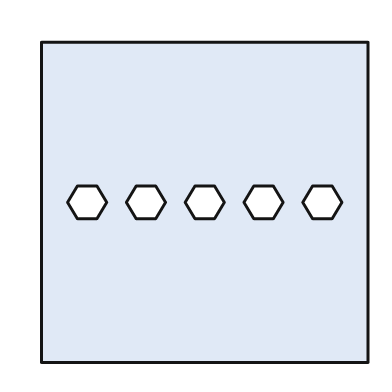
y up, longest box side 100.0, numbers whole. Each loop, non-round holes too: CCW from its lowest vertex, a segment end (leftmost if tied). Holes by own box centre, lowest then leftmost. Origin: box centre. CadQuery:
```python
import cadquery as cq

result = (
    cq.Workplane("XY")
    .moveTo(-50.0, -49.0)
    .lineTo(50.0, -49.0)
    .lineTo(50.0, 49.0)
    .lineTo(-50.0, 49.0)
    .close()
    .moveTo(-39.0, -5.0)
    .lineTo(-33.0, -5.0)
    .lineTo(-30.0, 0.0)
    .lineTo(-33.0, 5.0)
    .lineTo(-39.0, 5.0)
    .lineTo(-42.0, 0.0)
    .close()
    .moveTo(-21.0, -5.0)
    .lineTo(-15.0, -5.0)
    .lineTo(-12.0, 0.0)
    .lineTo(-15.0, 5.0)
    .lineTo(-21.0, 5.0)
    .lineTo(-24.0, 0.0)
    .close()
    .moveTo(-3.0, -5.0)
    .lineTo(3.0, -5.0)
    .lineTo(6.0, 0.0)
    .lineTo(3.0, 5.0)
    .lineTo(-3.0, 5.0)
    .lineTo(-6.0, 0.0)
    .close()
    .moveTo(15.0, -5.0)
    .lineTo(21.0, -5.0)
    .lineTo(24.0, 0.0)
    .lineTo(21.0, 5.0)
    .lineTo(15.0, 5.0)
    .lineTo(12.0, 0.0)
    .close()
    .moveTo(33.0, -5.0)
    .lineTo(39.0, -5.0)
    .lineTo(42.0, 0.0)
    .lineTo(39.0, 5.0)
    .lineTo(33.0, 5.0)
    .lineTo(30.0, 0.0)
    .close()
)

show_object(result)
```